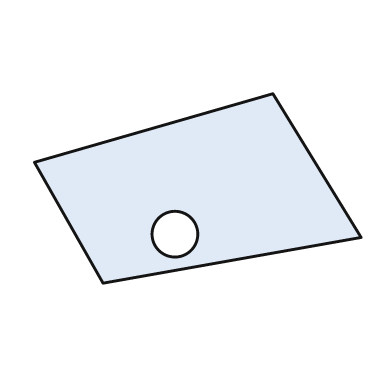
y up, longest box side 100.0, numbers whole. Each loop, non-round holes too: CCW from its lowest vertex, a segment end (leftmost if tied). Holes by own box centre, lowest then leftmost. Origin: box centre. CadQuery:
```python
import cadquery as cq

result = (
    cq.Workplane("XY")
    .moveTo(-29.0, -29.0)
    .lineTo(50.0, -15.0)
    .lineTo(23.0, 29.0)
    .lineTo(-50.0, 8.0)
    .close()
    .moveTo(-7.0, -14.0)
    .circle(7.0)
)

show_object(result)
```